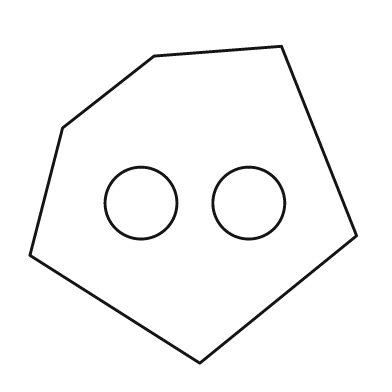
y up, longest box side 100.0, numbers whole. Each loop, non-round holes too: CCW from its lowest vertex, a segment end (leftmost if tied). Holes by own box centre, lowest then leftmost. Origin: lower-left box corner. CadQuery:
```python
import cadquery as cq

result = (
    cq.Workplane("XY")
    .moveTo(52.0, 0.0)
    .lineTo(100.0, 39.0)
    .lineTo(77.0, 97.0)
    .lineTo(38.0, 94.0)
    .lineTo(10.0, 72.0)
    .lineTo(0.0, 33.0)
    .close()
    .moveTo(34.0, 49.0)
    .circle(11.0)
    .moveTo(67.0, 49.0)
    .circle(11.0)
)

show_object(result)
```